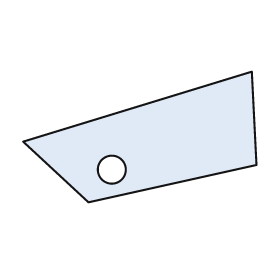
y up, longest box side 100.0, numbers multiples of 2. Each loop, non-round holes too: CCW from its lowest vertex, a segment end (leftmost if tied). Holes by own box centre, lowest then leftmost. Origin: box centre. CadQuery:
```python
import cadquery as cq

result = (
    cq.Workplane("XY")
    .moveTo(-22.0, -28.0)
    .lineTo(50.0, -12.0)
    .lineTo(48.0, 28.0)
    .lineTo(-50.0, -2.0)
    .close()
    .moveTo(-12.0, -14.0)
    .circle(6.0)
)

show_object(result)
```